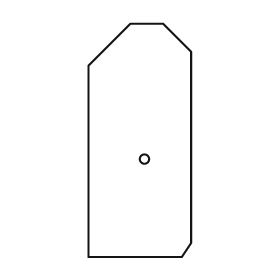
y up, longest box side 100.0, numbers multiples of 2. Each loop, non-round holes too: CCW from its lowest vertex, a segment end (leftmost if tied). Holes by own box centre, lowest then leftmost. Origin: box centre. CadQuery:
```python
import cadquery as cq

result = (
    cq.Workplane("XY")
    .moveTo(-22.0, -50.0)
    .lineTo(18.0, -50.0)
    .lineTo(22.0, -44.0)
    .lineTo(22.0, 38.0)
    .lineTo(10.0, 50.0)
    .lineTo(-4.0, 50.0)
    .lineTo(-22.0, 32.0)
    .close()
    .moveTo(2.0, -8.0)
    .circle(2.0)
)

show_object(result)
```